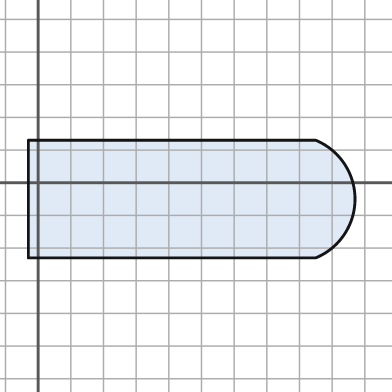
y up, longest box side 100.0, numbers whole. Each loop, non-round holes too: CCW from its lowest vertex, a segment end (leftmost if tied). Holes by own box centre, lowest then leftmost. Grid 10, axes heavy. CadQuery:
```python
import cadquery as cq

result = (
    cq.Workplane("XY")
    .moveTo(-3.0, -23.0)
    .lineTo(85.0, -23.0)
    .threePointArc((97.0, -5.0), (85.0, 13.0))
    .lineTo(-3.0, 13.0)
    .close()
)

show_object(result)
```